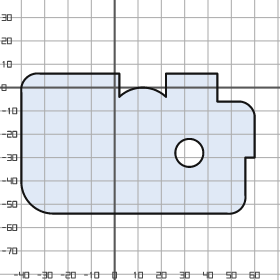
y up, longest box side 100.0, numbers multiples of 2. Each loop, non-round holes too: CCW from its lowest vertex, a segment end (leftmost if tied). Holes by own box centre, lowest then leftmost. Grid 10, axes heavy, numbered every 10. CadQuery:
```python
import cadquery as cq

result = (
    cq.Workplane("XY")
    .moveTo(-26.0, -54.0)
    .lineTo(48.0, -54.0)
    .threePointArc((54.0, -52.0), (56.0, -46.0))
    .lineTo(56.0, -30.0)
    .lineTo(60.0, -30.0)
    .lineTo(60.0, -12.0)
    .threePointArc((58.0, -8.0), (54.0, -6.0))
    .lineTo(44.0, -6.0)
    .lineTo(44.0, 6.0)
    .lineTo(22.0, 6.0)
    .lineTo(22.0, -4.0)
    .threePointArc((12.0, 0.0), (2.0, -4.0))
    .lineTo(2.0, 6.0)
    .lineTo(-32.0, 6.0)
    .threePointArc((-38.0, 4.0), (-40.0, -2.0))
    .lineTo(-40.0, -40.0)
    .threePointArc((-36.0, -50.0), (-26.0, -54.0))
    .close()
    .moveTo(32.0, -28.0)
    .circle(6.0)
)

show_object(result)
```